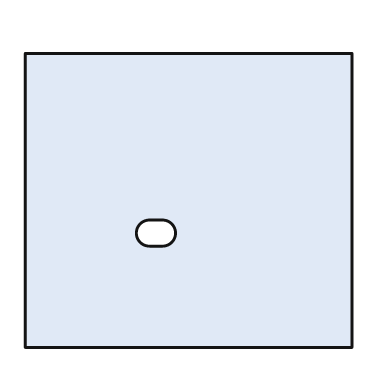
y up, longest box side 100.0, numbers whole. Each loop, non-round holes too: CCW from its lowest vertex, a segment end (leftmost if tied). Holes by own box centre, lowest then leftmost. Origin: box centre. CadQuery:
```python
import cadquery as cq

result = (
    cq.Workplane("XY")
    .moveTo(-50.0, -45.0)
    .lineTo(50.0, -45.0)
    .lineTo(50.0, 45.0)
    .lineTo(-50.0, 45.0)
    .close()
    .moveTo(-12.0, -14.0)
    .lineTo(-8.0, -14.0)
    .threePointArc((-4.0, -10.0), (-8.0, -6.0))
    .lineTo(-12.0, -6.0)
    .threePointArc((-16.0, -10.0), (-12.0, -14.0))
    .close()
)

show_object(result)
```